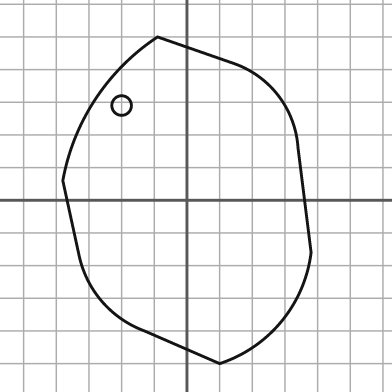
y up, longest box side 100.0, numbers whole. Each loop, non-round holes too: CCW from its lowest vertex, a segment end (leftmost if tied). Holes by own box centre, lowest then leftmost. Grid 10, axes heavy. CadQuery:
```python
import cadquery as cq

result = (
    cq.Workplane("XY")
    .moveTo(10.0, -50.0)
    .threePointArc((29.0, -37.0), (38.0, -16.0))
    .lineTo(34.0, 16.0)
    .threePointArc((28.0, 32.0), (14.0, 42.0))
    .lineTo(-9.0, 50.0)
    .threePointArc((-28.0, 31.0), (-38.0, 6.0))
    .lineTo(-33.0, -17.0)
    .threePointArc((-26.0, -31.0), (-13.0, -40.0))
    .close()
    .moveTo(-20.0, 29.0)
    .circle(3.0)
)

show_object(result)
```